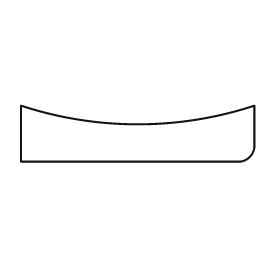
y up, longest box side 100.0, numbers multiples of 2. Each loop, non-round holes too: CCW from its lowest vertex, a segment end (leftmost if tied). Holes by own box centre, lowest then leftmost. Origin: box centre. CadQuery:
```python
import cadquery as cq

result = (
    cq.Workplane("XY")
    .moveTo(-50.0, -12.0)
    .lineTo(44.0, -12.0)
    .threePointArc((48.0, -10.0), (50.0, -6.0))
    .lineTo(50.0, 12.0)
    .threePointArc((0.0, 4.0), (-50.0, 12.0))
    .close()
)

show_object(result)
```